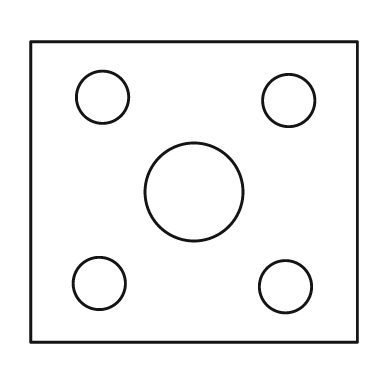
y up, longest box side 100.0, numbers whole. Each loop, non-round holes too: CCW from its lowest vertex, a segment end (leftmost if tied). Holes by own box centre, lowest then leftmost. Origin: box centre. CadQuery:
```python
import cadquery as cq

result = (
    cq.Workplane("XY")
    .moveTo(-50.0, -46.0)
    .lineTo(50.0, -46.0)
    .lineTo(50.0, 46.0)
    .lineTo(-50.0, 46.0)
    .close()
    .moveTo(28.0, -29.0)
    .circle(8.0)
    .moveTo(-29.0, -28.0)
    .circle(8.0)
    .moveTo(0.0, 0.0)
    .circle(15.0)
    .moveTo(29.0, 28.0)
    .circle(8.0)
    .moveTo(-28.0, 29.0)
    .circle(8.0)
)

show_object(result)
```